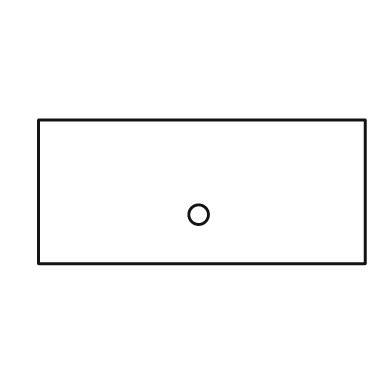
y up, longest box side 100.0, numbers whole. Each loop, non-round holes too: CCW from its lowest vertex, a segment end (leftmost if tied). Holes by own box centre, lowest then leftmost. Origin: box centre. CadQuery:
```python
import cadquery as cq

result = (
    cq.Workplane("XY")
    .moveTo(-50.0, -22.0)
    .lineTo(50.0, -22.0)
    .lineTo(50.0, 22.0)
    .lineTo(-50.0, 22.0)
    .close()
    .moveTo(-1.0, -7.0)
    .circle(3.0)
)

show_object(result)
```